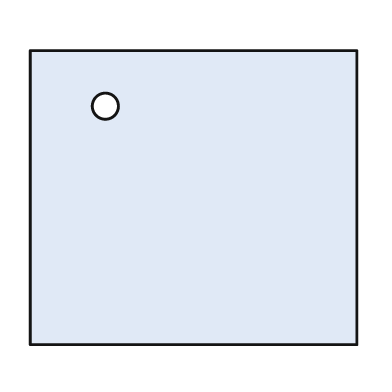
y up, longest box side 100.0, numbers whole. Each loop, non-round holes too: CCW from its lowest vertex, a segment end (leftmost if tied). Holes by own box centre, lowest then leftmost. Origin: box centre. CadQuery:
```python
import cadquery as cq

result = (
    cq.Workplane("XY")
    .moveTo(-50.0, -45.0)
    .lineTo(50.0, -45.0)
    .lineTo(50.0, 45.0)
    .lineTo(-50.0, 45.0)
    .close()
    .moveTo(-27.0, 28.0)
    .circle(4.0)
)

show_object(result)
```